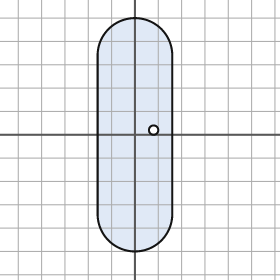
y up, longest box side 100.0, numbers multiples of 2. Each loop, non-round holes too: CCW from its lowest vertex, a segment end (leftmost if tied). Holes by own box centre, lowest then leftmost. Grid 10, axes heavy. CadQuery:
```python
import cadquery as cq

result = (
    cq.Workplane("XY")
    .moveTo(-16.0, -34.0)
    .threePointArc((0.0, -50.0), (16.0, -34.0))
    .lineTo(16.0, 34.0)
    .threePointArc((0.0, 50.0), (-16.0, 34.0))
    .close()
    .moveTo(8.0, 2.0)
    .circle(2.0)
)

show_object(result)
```